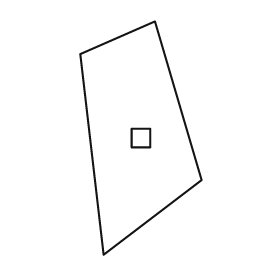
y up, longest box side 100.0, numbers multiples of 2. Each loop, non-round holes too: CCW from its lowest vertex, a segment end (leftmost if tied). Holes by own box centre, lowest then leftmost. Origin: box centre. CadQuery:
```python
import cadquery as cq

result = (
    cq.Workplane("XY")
    .moveTo(-16.0, -50.0)
    .lineTo(26.0, -18.0)
    .lineTo(6.0, 50.0)
    .lineTo(-26.0, 36.0)
    .close()
    .moveTo(-4.0, -4.0)
    .lineTo(4.0, -4.0)
    .lineTo(4.0, 4.0)
    .lineTo(-4.0, 4.0)
    .close()
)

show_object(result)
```